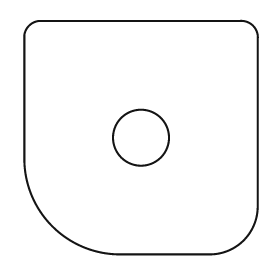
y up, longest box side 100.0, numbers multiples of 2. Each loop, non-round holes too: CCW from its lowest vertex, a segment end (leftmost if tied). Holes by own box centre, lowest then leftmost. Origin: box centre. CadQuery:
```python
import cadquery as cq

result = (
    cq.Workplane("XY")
    .moveTo(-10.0, -50.0)
    .lineTo(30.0, -50.0)
    .threePointArc((44.0, -44.0), (50.0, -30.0))
    .lineTo(50.0, 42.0)
    .threePointArc((48.0, 48.0), (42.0, 50.0))
    .lineTo(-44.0, 50.0)
    .threePointArc((-48.0, 48.0), (-50.0, 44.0))
    .lineTo(-50.0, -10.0)
    .threePointArc((-38.0, -38.0), (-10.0, -50.0))
    .close()
    .moveTo(0.0, 0.0)
    .circle(12.0)
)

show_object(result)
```